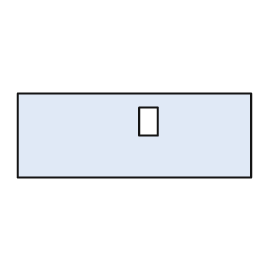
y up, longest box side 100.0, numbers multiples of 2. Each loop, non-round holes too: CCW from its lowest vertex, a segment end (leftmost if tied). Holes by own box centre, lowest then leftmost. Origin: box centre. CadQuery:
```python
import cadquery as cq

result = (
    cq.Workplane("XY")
    .moveTo(-50.0, -18.0)
    .lineTo(50.0, -18.0)
    .lineTo(50.0, 18.0)
    .lineTo(-50.0, 18.0)
    .close()
    .moveTo(2.0, 0.0)
    .lineTo(10.0, 0.0)
    .lineTo(10.0, 12.0)
    .lineTo(2.0, 12.0)
    .close()
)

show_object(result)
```